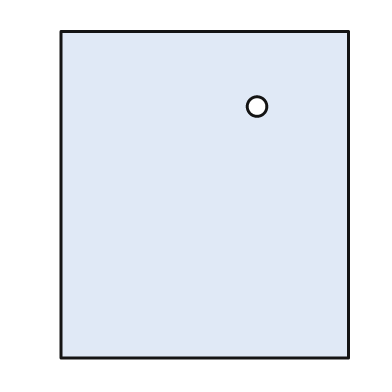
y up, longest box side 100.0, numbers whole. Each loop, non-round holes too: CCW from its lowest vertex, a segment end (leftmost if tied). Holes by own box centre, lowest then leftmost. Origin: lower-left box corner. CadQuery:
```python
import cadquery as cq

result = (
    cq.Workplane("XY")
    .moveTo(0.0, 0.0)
    .lineTo(88.0, 0.0)
    .lineTo(88.0, 100.0)
    .lineTo(0.0, 100.0)
    .close()
    .moveTo(60.0, 77.0)
    .circle(3.0)
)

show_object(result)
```